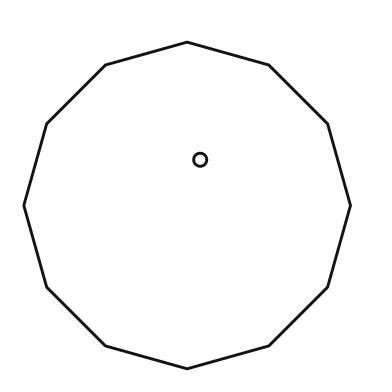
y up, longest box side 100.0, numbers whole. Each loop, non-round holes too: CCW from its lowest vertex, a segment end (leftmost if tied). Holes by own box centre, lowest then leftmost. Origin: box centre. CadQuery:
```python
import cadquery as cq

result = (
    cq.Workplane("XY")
    .moveTo(0.0, -50.0)
    .lineTo(25.0, -43.0)
    .lineTo(43.0, -25.0)
    .lineTo(50.0, 0.0)
    .lineTo(43.0, 25.0)
    .lineTo(25.0, 43.0)
    .lineTo(0.0, 50.0)
    .lineTo(-25.0, 43.0)
    .lineTo(-43.0, 25.0)
    .lineTo(-50.0, 0.0)
    .lineTo(-43.0, -25.0)
    .lineTo(-25.0, -43.0)
    .close()
    .moveTo(4.0, 14.0)
    .circle(2.0)
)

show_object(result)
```